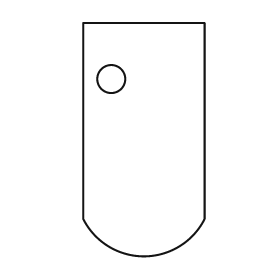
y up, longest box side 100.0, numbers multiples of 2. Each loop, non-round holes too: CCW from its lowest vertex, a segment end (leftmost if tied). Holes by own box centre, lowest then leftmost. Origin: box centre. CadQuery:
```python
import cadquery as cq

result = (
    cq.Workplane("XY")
    .moveTo(-26.0, -34.0)
    .threePointArc((0.0, -50.0), (26.0, -34.0))
    .lineTo(26.0, 50.0)
    .lineTo(-26.0, 50.0)
    .close()
    .moveTo(-14.0, 26.0)
    .circle(6.0)
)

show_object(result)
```